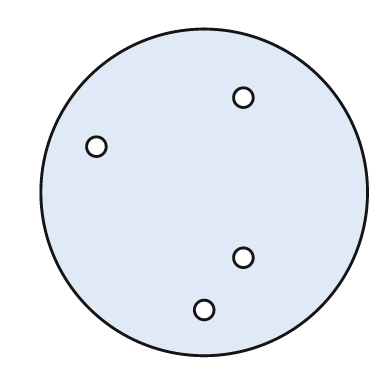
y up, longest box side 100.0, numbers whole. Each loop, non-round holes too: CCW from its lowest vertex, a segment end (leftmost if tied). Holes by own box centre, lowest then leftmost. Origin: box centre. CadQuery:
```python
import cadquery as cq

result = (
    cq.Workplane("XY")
    .moveTo(0.0, 0.0)
    .circle(50.0)
    .moveTo(0.0, -36.0)
    .circle(3.0)
    .moveTo(12.0, -20.0)
    .circle(3.0)
    .moveTo(-33.0, 14.0)
    .circle(3.0)
    .moveTo(12.0, 29.0)
    .circle(3.0)
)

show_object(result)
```